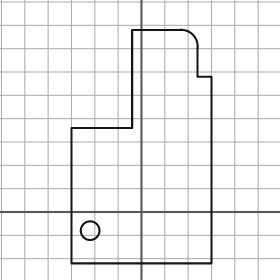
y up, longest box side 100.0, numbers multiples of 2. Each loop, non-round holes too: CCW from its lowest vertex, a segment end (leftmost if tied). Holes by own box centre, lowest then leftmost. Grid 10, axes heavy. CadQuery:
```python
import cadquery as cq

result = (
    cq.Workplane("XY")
    .moveTo(-30.0, -22.0)
    .lineTo(30.0, -22.0)
    .lineTo(30.0, 58.0)
    .lineTo(24.0, 58.0)
    .lineTo(24.0, 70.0)
    .threePointArc((22.0, 76.0), (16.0, 78.0))
    .lineTo(-4.0, 78.0)
    .lineTo(-4.0, 36.0)
    .lineTo(-30.0, 36.0)
    .close()
    .moveTo(-22.0, -8.0)
    .circle(4.0)
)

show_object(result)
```